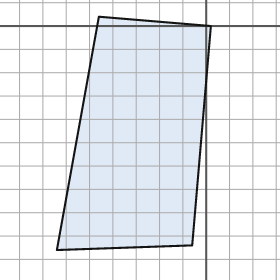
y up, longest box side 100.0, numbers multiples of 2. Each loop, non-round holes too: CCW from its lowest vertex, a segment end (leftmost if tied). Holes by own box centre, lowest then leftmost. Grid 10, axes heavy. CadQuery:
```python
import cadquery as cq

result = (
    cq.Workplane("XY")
    .moveTo(-64.0, -96.0)
    .lineTo(-6.0, -94.0)
    .lineTo(2.0, 0.0)
    .lineTo(-46.0, 4.0)
    .close()
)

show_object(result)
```